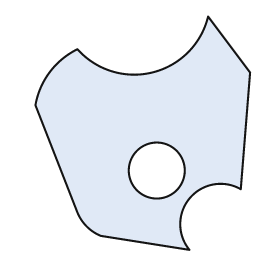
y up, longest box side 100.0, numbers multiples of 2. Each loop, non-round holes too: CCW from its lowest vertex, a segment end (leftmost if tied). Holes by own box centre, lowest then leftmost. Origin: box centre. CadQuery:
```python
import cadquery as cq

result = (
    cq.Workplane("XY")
    .moveTo(20.0, -50.0)
    .threePointArc((20.0, -28.0), (42.0, -24.0))
    .lineTo(46.0, 26.0)
    .lineTo(28.0, 50.0)
    .threePointArc((4.0, 26.0), (-28.0, 36.0))
    .threePointArc((-40.0, 26.0), (-46.0, 12.0))
    .lineTo(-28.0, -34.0)
    .threePointArc((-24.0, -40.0), (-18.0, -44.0))
    .close()
    .moveTo(6.0, -16.0)
    .circle(12.0)
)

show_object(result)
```